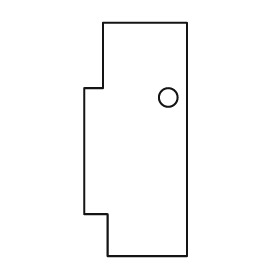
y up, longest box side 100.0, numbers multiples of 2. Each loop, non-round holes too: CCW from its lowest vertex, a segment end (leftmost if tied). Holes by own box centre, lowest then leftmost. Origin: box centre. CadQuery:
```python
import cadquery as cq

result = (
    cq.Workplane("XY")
    .moveTo(-12.0, -50.0)
    .lineTo(22.0, -50.0)
    .lineTo(22.0, 50.0)
    .lineTo(-14.0, 50.0)
    .lineTo(-14.0, 22.0)
    .lineTo(-22.0, 22.0)
    .lineTo(-22.0, -32.0)
    .lineTo(-12.0, -32.0)
    .close()
    .moveTo(14.0, 18.0)
    .circle(4.0)
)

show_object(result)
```